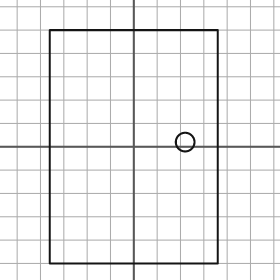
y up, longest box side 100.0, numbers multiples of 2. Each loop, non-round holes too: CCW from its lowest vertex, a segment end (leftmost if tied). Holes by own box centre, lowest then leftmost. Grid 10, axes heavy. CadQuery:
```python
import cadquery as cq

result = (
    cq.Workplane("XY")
    .moveTo(-36.0, -50.0)
    .lineTo(36.0, -50.0)
    .lineTo(36.0, 50.0)
    .lineTo(-36.0, 50.0)
    .close()
    .moveTo(22.0, 2.0)
    .circle(4.0)
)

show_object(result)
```